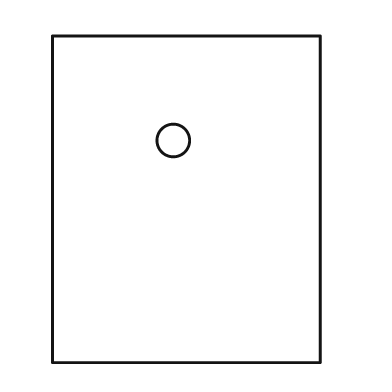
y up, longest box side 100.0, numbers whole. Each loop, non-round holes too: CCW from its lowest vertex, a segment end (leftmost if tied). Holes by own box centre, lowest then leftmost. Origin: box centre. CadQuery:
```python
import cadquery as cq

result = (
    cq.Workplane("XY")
    .moveTo(-41.0, -50.0)
    .lineTo(41.0, -50.0)
    .lineTo(41.0, 50.0)
    .lineTo(-41.0, 50.0)
    .close()
    .moveTo(-4.0, 18.0)
    .circle(5.0)
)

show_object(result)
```